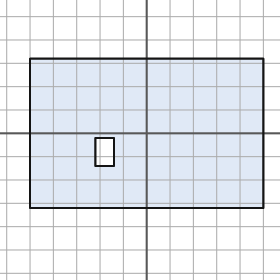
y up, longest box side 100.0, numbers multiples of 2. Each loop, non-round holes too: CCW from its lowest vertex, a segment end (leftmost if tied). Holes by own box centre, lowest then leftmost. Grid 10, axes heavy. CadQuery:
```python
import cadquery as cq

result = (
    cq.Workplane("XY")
    .moveTo(-50.0, -32.0)
    .lineTo(50.0, -32.0)
    .lineTo(50.0, 32.0)
    .lineTo(-50.0, 32.0)
    .close()
    .moveTo(-22.0, -14.0)
    .lineTo(-14.0, -14.0)
    .lineTo(-14.0, -2.0)
    .lineTo(-22.0, -2.0)
    .close()
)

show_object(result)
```